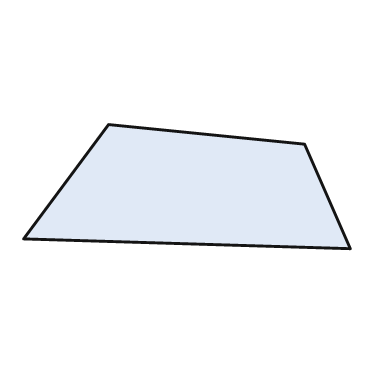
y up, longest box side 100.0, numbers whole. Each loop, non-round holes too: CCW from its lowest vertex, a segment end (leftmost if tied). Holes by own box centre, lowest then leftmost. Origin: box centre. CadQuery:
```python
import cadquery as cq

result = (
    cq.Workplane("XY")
    .moveTo(50.0, -19.0)
    .lineTo(36.0, 13.0)
    .lineTo(-24.0, 19.0)
    .lineTo(-50.0, -16.0)
    .close()
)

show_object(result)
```